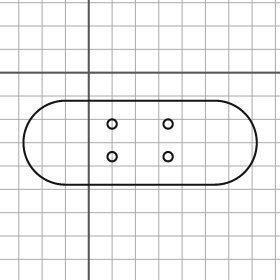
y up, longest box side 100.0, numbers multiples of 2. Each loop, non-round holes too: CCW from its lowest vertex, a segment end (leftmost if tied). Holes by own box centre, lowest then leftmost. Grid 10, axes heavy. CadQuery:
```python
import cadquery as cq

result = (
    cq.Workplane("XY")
    .moveTo(-10.0, -48.0)
    .lineTo(54.0, -48.0)
    .threePointArc((72.0, -30.0), (54.0, -12.0))
    .lineTo(-10.0, -12.0)
    .threePointArc((-28.0, -30.0), (-10.0, -48.0))
    .close()
    .moveTo(10.0, -36.0)
    .circle(2.0)
    .moveTo(34.0, -36.0)
    .circle(2.0)
    .moveTo(10.0, -22.0)
    .circle(2.0)
    .moveTo(34.0, -22.0)
    .circle(2.0)
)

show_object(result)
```